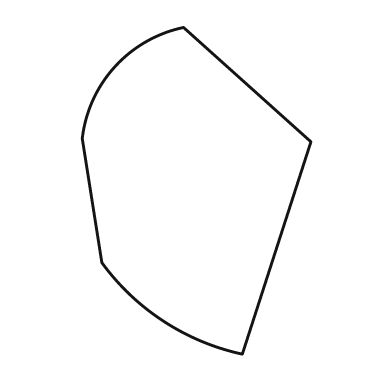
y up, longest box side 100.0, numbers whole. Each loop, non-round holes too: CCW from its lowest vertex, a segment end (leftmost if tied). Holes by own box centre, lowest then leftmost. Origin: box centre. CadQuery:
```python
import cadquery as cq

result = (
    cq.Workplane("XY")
    .moveTo(14.0, -50.0)
    .lineTo(35.0, 15.0)
    .lineTo(-4.0, 50.0)
    .threePointArc((-25.0, 38.0), (-35.0, 16.0))
    .lineTo(-29.0, -22.0)
    .threePointArc((-10.0, -40.0), (14.0, -50.0))
    .close()
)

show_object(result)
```